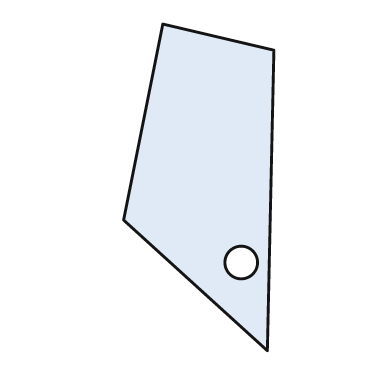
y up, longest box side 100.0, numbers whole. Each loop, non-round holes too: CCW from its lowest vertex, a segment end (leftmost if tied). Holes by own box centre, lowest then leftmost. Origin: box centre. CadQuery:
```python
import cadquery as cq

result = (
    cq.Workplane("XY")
    .moveTo(21.0, -50.0)
    .lineTo(23.0, 42.0)
    .lineTo(-11.0, 50.0)
    .lineTo(-23.0, -10.0)
    .close()
    .moveTo(13.0, -23.0)
    .circle(5.0)
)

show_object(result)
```